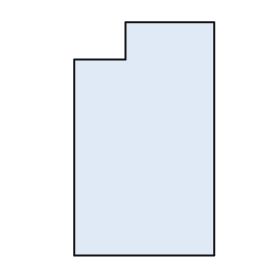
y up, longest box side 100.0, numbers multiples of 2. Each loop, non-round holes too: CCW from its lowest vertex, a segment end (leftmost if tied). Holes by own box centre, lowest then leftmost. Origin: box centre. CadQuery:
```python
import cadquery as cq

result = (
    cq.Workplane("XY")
    .moveTo(-30.0, -50.0)
    .lineTo(30.0, -50.0)
    .lineTo(30.0, 50.0)
    .lineTo(-8.0, 50.0)
    .lineTo(-8.0, 34.0)
    .lineTo(-30.0, 34.0)
    .close()
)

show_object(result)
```